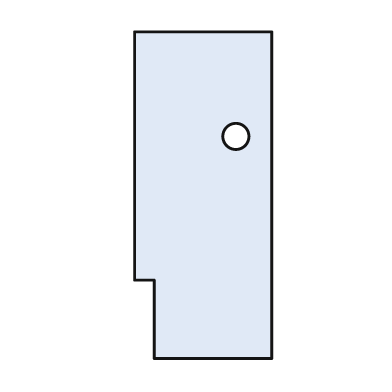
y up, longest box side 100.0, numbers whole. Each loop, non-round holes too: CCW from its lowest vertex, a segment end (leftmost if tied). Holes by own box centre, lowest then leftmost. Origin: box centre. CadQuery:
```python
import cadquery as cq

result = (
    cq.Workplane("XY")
    .moveTo(-15.0, -50.0)
    .lineTo(21.0, -50.0)
    .lineTo(21.0, 50.0)
    .lineTo(-21.0, 50.0)
    .lineTo(-21.0, -26.0)
    .lineTo(-15.0, -26.0)
    .close()
    .moveTo(10.0, 18.0)
    .circle(4.0)
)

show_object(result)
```